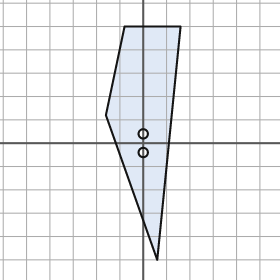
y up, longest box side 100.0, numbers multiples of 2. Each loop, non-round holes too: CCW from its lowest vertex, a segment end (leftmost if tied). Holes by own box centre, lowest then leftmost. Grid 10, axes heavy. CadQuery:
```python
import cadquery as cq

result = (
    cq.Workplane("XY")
    .moveTo(6.0, -50.0)
    .lineTo(16.0, 50.0)
    .lineTo(-8.0, 50.0)
    .lineTo(-16.0, 12.0)
    .close()
    .moveTo(0.0, -4.0)
    .circle(2.0)
    .moveTo(0.0, 4.0)
    .circle(2.0)
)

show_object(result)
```